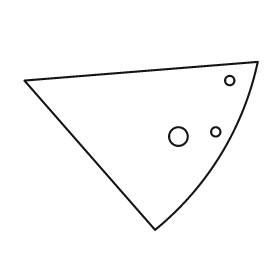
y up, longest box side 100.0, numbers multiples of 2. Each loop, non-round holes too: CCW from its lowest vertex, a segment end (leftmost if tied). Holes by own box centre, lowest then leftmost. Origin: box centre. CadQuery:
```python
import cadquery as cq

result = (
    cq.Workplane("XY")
    .moveTo(6.0, -36.0)
    .threePointArc((34.0, -4.0), (50.0, 36.0))
    .lineTo(-50.0, 28.0)
    .close()
    .moveTo(16.0, 4.0)
    .circle(4.0)
    .moveTo(32.0, 6.0)
    .circle(2.0)
    .moveTo(38.0, 28.0)
    .circle(2.0)
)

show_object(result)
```